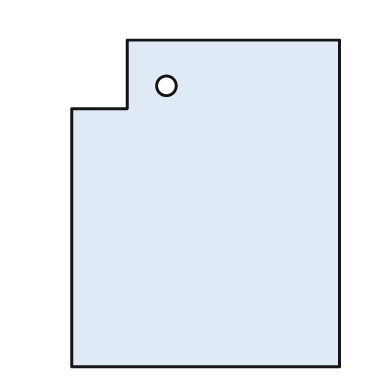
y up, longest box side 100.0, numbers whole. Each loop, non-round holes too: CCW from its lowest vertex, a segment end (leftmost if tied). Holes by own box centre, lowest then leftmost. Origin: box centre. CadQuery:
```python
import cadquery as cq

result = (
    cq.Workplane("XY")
    .moveTo(-41.0, -50.0)
    .lineTo(41.0, -50.0)
    .lineTo(41.0, 50.0)
    .lineTo(-24.0, 50.0)
    .lineTo(-24.0, 29.0)
    .lineTo(-41.0, 29.0)
    .close()
    .moveTo(-12.0, 36.0)
    .circle(3.0)
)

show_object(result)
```